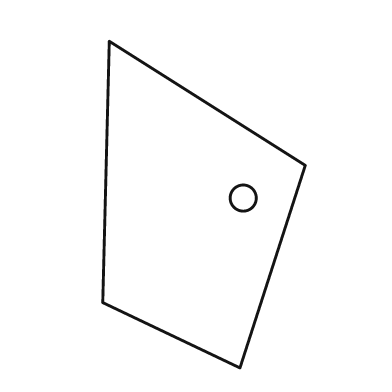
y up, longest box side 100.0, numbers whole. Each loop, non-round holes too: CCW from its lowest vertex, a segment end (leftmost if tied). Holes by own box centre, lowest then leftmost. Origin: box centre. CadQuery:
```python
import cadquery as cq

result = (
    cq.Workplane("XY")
    .moveTo(11.0, -50.0)
    .lineTo(31.0, 12.0)
    .lineTo(-29.0, 50.0)
    .lineTo(-31.0, -30.0)
    .close()
    .moveTo(12.0, 2.0)
    .circle(4.0)
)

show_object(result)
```